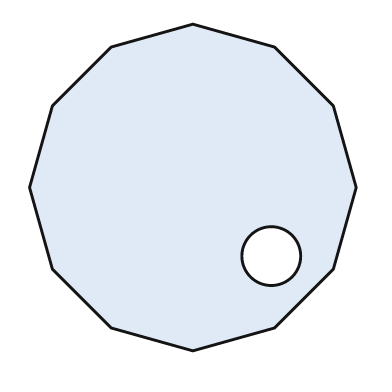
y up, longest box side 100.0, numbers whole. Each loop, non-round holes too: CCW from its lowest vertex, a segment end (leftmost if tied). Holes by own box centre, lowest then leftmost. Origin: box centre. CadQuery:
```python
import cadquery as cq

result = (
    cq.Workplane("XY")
    .moveTo(0.0, -50.0)
    .lineTo(25.0, -43.0)
    .lineTo(43.0, -25.0)
    .lineTo(50.0, 0.0)
    .lineTo(43.0, 25.0)
    .lineTo(25.0, 43.0)
    .lineTo(0.0, 50.0)
    .lineTo(-25.0, 43.0)
    .lineTo(-43.0, 25.0)
    .lineTo(-50.0, 0.0)
    .lineTo(-43.0, -25.0)
    .lineTo(-25.0, -43.0)
    .close()
    .moveTo(24.0, -21.0)
    .circle(9.0)
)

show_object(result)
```